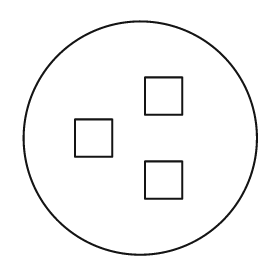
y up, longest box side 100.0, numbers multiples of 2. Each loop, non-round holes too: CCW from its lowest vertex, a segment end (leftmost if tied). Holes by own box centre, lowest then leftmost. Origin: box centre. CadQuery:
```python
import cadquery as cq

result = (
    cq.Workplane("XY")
    .moveTo(0.0, 0.0)
    .circle(50.0)
    .moveTo(2.0, -26.0)
    .lineTo(18.0, -26.0)
    .lineTo(18.0, -10.0)
    .lineTo(2.0, -10.0)
    .close()
    .moveTo(-28.0, -8.0)
    .lineTo(-12.0, -8.0)
    .lineTo(-12.0, 8.0)
    .lineTo(-28.0, 8.0)
    .close()
    .moveTo(2.0, 10.0)
    .lineTo(18.0, 10.0)
    .lineTo(18.0, 26.0)
    .lineTo(2.0, 26.0)
    .close()
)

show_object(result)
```